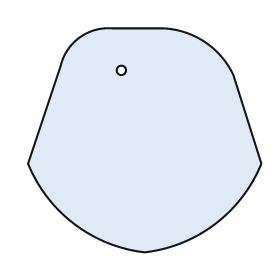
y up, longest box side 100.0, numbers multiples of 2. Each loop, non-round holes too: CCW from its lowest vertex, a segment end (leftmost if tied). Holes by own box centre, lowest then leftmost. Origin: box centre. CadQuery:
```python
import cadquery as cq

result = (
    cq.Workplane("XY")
    .moveTo(0.0, -48.0)
    .threePointArc((30.0, -36.0), (50.0, -10.0))
    .lineTo(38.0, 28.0)
    .threePointArc((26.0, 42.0), (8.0, 48.0))
    .lineTo(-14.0, 48.0)
    .threePointArc((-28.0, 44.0), (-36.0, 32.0))
    .lineTo(-50.0, -10.0)
    .threePointArc((-30.0, -36.0), (0.0, -48.0))
    .close()
    .moveTo(-10.0, 30.0)
    .circle(2.0)
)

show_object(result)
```